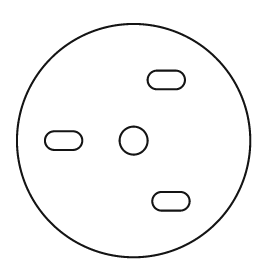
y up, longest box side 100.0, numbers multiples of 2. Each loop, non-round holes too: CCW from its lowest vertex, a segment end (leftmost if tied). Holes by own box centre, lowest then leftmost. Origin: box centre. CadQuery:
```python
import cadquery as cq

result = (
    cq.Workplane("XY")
    .moveTo(0.0, 0.0)
    .circle(50.0)
    .moveTo(12.0, -30.0)
    .lineTo(20.0, -30.0)
    .threePointArc((24.0, -26.0), (20.0, -22.0))
    .lineTo(12.0, -22.0)
    .threePointArc((8.0, -26.0), (12.0, -30.0))
    .close()
    .moveTo(-34.0, -4.0)
    .lineTo(-26.0, -4.0)
    .threePointArc((-22.0, 0.0), (-26.0, 4.0))
    .lineTo(-34.0, 4.0)
    .threePointArc((-38.0, 0.0), (-34.0, -4.0))
    .close()
    .moveTo(0.0, 0.0)
    .circle(6.0)
    .moveTo(10.0, 22.0)
    .lineTo(18.0, 22.0)
    .threePointArc((22.0, 26.0), (18.0, 30.0))
    .lineTo(10.0, 30.0)
    .threePointArc((6.0, 26.0), (10.0, 22.0))
    .close()
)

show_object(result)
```